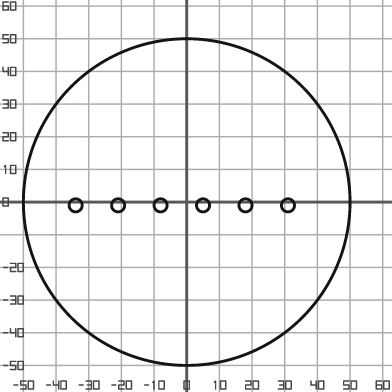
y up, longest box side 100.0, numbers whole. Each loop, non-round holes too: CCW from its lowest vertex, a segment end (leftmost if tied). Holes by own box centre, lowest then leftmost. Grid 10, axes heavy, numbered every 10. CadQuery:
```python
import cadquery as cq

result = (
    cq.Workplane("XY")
    .moveTo(0.0, 0.0)
    .circle(50.0)
    .moveTo(-34.0, -1.0)
    .circle(2.0)
    .moveTo(-21.0, -1.0)
    .circle(2.0)
    .moveTo(-8.0, -1.0)
    .circle(2.0)
    .moveTo(5.0, -1.0)
    .circle(2.0)
    .moveTo(18.0, -1.0)
    .circle(2.0)
    .moveTo(31.0, -1.0)
    .circle(2.0)
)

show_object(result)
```